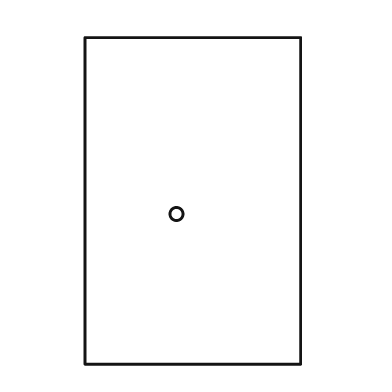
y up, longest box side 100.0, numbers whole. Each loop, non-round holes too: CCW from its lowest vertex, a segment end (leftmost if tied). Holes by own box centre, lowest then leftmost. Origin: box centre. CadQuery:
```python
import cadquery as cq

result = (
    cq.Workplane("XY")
    .moveTo(-33.0, -50.0)
    .lineTo(33.0, -50.0)
    .lineTo(33.0, 50.0)
    .lineTo(-33.0, 50.0)
    .close()
    .moveTo(-5.0, -4.0)
    .circle(2.0)
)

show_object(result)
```